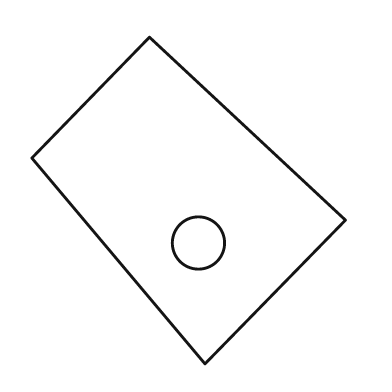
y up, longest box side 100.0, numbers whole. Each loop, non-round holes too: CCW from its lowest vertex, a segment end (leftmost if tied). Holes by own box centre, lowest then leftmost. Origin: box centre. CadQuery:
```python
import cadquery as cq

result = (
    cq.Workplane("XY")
    .moveTo(5.0, -50.0)
    .lineTo(48.0, -6.0)
    .lineTo(-12.0, 50.0)
    .lineTo(-48.0, 13.0)
    .close()
    .moveTo(3.0, -13.0)
    .circle(8.0)
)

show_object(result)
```